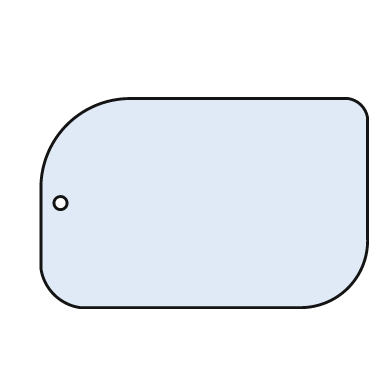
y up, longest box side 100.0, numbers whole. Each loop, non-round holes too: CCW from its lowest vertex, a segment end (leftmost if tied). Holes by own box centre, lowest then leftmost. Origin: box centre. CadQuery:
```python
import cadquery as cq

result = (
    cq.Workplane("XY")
    .moveTo(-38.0, -32.0)
    .lineTo(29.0, -32.0)
    .threePointArc((44.0, -26.0), (50.0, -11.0))
    .lineTo(50.0, 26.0)
    .threePointArc((48.0, 30.0), (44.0, 32.0))
    .lineTo(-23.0, 32.0)
    .threePointArc((-42.0, 24.0), (-50.0, 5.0))
    .lineTo(-50.0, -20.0)
    .threePointArc((-46.0, -28.0), (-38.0, -32.0))
    .close()
    .moveTo(-44.0, 0.0)
    .circle(2.0)
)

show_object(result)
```